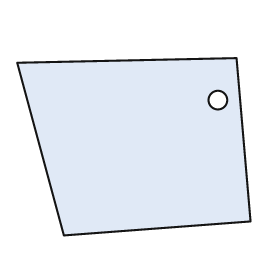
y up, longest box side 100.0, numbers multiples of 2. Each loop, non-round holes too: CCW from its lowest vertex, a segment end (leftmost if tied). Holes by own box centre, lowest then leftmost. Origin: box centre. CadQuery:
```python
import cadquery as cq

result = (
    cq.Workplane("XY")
    .moveTo(-30.0, -38.0)
    .lineTo(50.0, -32.0)
    .lineTo(44.0, 38.0)
    .lineTo(-50.0, 36.0)
    .close()
    .moveTo(36.0, 20.0)
    .circle(4.0)
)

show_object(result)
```